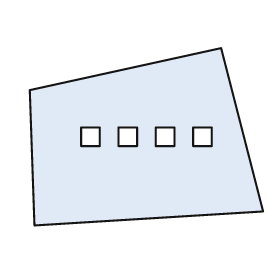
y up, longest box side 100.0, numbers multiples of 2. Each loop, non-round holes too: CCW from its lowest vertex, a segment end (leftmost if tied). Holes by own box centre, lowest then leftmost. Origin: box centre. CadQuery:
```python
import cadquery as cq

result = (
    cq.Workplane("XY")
    .moveTo(-48.0, -38.0)
    .lineTo(50.0, -32.0)
    .lineTo(32.0, 38.0)
    .lineTo(-50.0, 20.0)
    .close()
    .moveTo(-28.0, -4.0)
    .lineTo(-20.0, -4.0)
    .lineTo(-20.0, 4.0)
    .lineTo(-28.0, 4.0)
    .close()
    .moveTo(-12.0, -4.0)
    .lineTo(-4.0, -4.0)
    .lineTo(-4.0, 4.0)
    .lineTo(-12.0, 4.0)
    .close()
    .moveTo(4.0, -4.0)
    .lineTo(12.0, -4.0)
    .lineTo(12.0, 4.0)
    .lineTo(4.0, 4.0)
    .close()
    .moveTo(20.0, -4.0)
    .lineTo(28.0, -4.0)
    .lineTo(28.0, 4.0)
    .lineTo(20.0, 4.0)
    .close()
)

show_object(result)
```